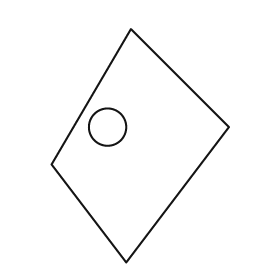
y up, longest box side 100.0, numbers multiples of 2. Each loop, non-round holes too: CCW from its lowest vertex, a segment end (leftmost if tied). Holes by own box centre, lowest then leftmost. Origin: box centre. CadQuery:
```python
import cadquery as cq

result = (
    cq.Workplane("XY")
    .moveTo(-6.0, -50.0)
    .lineTo(38.0, 8.0)
    .lineTo(-4.0, 50.0)
    .lineTo(-38.0, -8.0)
    .close()
    .moveTo(-14.0, 8.0)
    .circle(8.0)
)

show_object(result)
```